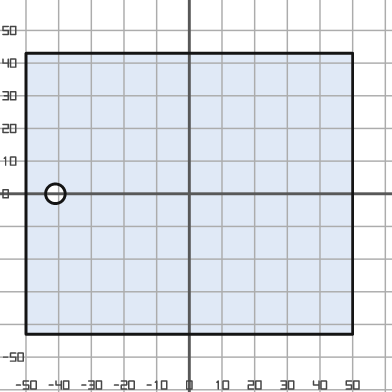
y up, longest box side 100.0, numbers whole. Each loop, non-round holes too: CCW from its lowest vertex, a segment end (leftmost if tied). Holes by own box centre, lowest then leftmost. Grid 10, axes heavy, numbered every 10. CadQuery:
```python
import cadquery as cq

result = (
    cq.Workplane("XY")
    .moveTo(-50.0, -43.0)
    .lineTo(50.0, -43.0)
    .lineTo(50.0, 43.0)
    .lineTo(-50.0, 43.0)
    .close()
    .moveTo(-41.0, 0.0)
    .circle(3.0)
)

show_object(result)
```